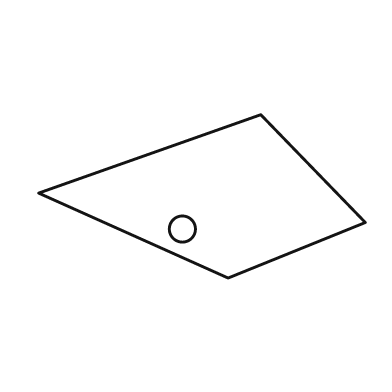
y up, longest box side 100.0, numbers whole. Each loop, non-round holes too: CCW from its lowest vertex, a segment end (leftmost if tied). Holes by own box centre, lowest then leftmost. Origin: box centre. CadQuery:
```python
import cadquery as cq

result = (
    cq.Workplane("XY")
    .moveTo(8.0, -25.0)
    .lineTo(50.0, -8.0)
    .lineTo(18.0, 25.0)
    .lineTo(-50.0, 1.0)
    .close()
    .moveTo(-6.0, -10.0)
    .circle(4.0)
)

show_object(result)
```